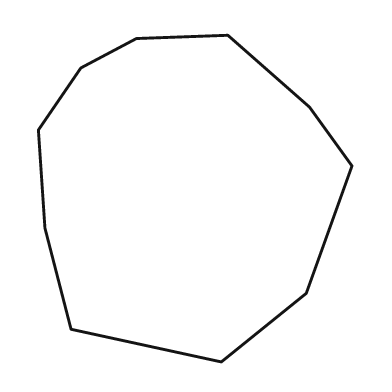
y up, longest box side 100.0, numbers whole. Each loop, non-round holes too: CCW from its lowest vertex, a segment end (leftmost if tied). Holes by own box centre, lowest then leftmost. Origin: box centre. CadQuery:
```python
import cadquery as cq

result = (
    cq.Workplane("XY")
    .moveTo(8.0, -50.0)
    .lineTo(34.0, -29.0)
    .lineTo(48.0, 10.0)
    .lineTo(35.0, 28.0)
    .lineTo(10.0, 50.0)
    .lineTo(-18.0, 49.0)
    .lineTo(-35.0, 40.0)
    .lineTo(-48.0, 21.0)
    .lineTo(-46.0, -9.0)
    .lineTo(-38.0, -40.0)
    .close()
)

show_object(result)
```